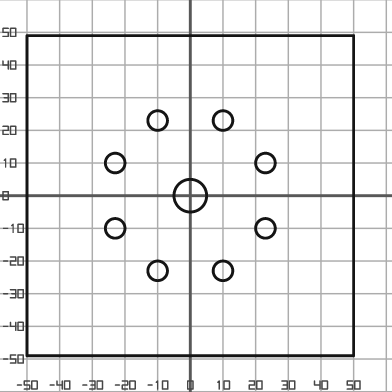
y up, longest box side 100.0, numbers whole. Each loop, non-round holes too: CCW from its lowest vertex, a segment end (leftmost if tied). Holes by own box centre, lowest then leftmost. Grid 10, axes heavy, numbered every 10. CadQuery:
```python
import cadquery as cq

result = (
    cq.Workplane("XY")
    .moveTo(-50.0, -49.0)
    .lineTo(50.0, -49.0)
    .lineTo(50.0, 49.0)
    .lineTo(-50.0, 49.0)
    .close()
    .moveTo(-10.0, -23.0)
    .circle(3.0)
    .moveTo(10.0, -23.0)
    .circle(3.0)
    .moveTo(-23.0, -10.0)
    .circle(3.0)
    .moveTo(23.0, -10.0)
    .circle(3.0)
    .moveTo(0.0, 0.0)
    .circle(5.0)
    .moveTo(-23.0, 10.0)
    .circle(3.0)
    .moveTo(23.0, 10.0)
    .circle(3.0)
    .moveTo(-10.0, 23.0)
    .circle(3.0)
    .moveTo(10.0, 23.0)
    .circle(3.0)
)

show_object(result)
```